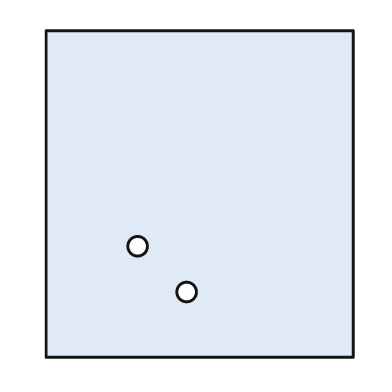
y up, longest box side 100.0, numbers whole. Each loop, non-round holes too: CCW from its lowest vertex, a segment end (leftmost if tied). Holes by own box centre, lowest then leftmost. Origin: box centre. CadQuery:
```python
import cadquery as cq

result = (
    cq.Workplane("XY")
    .moveTo(-47.0, -50.0)
    .lineTo(47.0, -50.0)
    .lineTo(47.0, 50.0)
    .lineTo(-47.0, 50.0)
    .close()
    .moveTo(-4.0, -30.0)
    .circle(3.0)
    .moveTo(-19.0, -16.0)
    .circle(3.0)
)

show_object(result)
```